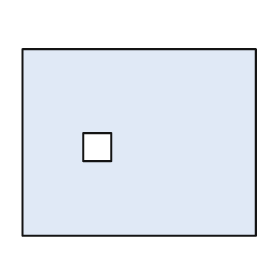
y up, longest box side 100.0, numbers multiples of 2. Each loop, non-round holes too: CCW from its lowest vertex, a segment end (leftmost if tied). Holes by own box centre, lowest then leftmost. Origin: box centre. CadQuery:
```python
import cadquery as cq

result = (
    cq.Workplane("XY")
    .moveTo(-50.0, -40.0)
    .lineTo(50.0, -40.0)
    .lineTo(50.0, 40.0)
    .lineTo(-50.0, 40.0)
    .close()
    .moveTo(-24.0, -8.0)
    .lineTo(-12.0, -8.0)
    .lineTo(-12.0, 4.0)
    .lineTo(-24.0, 4.0)
    .close()
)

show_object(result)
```